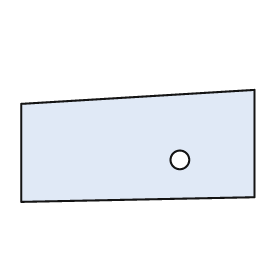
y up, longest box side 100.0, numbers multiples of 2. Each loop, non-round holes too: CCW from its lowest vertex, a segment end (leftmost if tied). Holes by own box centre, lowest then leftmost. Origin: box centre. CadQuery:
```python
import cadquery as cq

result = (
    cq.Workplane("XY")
    .moveTo(-50.0, -24.0)
    .lineTo(50.0, -22.0)
    .lineTo(50.0, 24.0)
    .lineTo(-50.0, 18.0)
    .close()
    .moveTo(18.0, -6.0)
    .circle(4.0)
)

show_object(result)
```